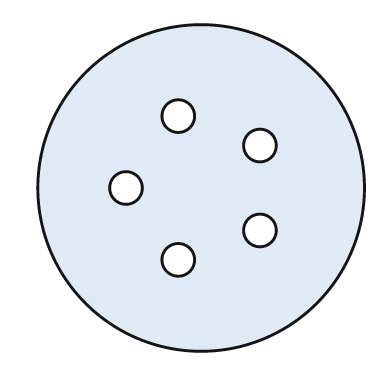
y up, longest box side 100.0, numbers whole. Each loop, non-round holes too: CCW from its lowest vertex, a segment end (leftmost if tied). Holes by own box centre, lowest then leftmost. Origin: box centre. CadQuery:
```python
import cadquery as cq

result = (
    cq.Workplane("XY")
    .moveTo(0.0, 0.0)
    .circle(50.0)
    .moveTo(-7.0, -22.0)
    .circle(5.0)
    .moveTo(18.0, -13.0)
    .circle(5.0)
    .moveTo(-23.0, 0.0)
    .circle(5.0)
    .moveTo(18.0, 13.0)
    .circle(5.0)
    .moveTo(-7.0, 22.0)
    .circle(5.0)
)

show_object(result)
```